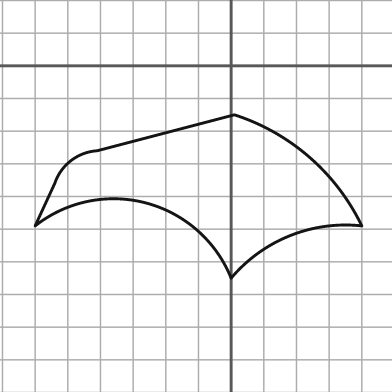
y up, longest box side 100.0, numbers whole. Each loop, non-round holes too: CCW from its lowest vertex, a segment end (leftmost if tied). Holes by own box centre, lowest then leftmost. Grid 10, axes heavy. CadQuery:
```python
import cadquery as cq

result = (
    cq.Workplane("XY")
    .moveTo(0.0, -65.0)
    .threePointArc((18.0, -52.0), (40.0, -49.0))
    .threePointArc((24.0, -28.0), (1.0, -15.0))
    .lineTo(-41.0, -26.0)
    .threePointArc((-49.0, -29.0), (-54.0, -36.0))
    .lineTo(-60.0, -49.0)
    .threePointArc((-26.0, -42.0), (0.0, -65.0))
    .close()
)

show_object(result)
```